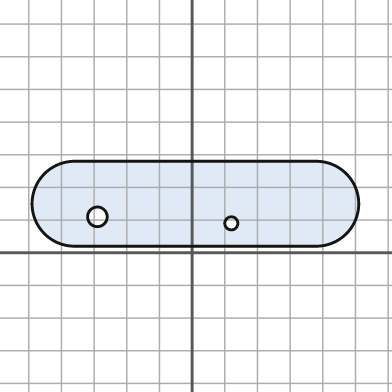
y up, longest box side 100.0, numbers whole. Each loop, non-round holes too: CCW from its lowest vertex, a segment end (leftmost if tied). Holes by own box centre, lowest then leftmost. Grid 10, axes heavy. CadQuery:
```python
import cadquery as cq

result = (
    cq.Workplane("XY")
    .moveTo(-36.0, 2.0)
    .lineTo(38.0, 2.0)
    .threePointArc((51.0, 15.0), (38.0, 28.0))
    .lineTo(-36.0, 28.0)
    .threePointArc((-49.0, 15.0), (-36.0, 2.0))
    .close()
    .moveTo(12.0, 9.0)
    .circle(2.0)
    .moveTo(-29.0, 11.0)
    .circle(3.0)
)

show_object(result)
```